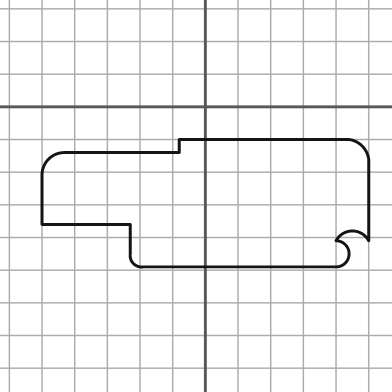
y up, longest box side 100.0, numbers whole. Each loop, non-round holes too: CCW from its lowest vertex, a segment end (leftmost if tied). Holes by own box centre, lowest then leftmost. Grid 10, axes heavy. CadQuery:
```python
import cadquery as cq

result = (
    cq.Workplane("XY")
    .moveTo(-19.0, -49.0)
    .lineTo(40.0, -49.0)
    .threePointArc((44.0, -45.0), (40.0, -41.0))
    .threePointArc((45.0, -38.0), (50.0, -41.0))
    .lineTo(50.0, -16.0)
    .threePointArc((48.0, -12.0), (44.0, -10.0))
    .lineTo(-8.0, -10.0)
    .lineTo(-8.0, -14.0)
    .lineTo(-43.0, -14.0)
    .threePointArc((-48.0, -16.0), (-50.0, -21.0))
    .lineTo(-50.0, -36.0)
    .lineTo(-23.0, -36.0)
    .lineTo(-23.0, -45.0)
    .threePointArc((-22.0, -48.0), (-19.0, -49.0))
    .close()
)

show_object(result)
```